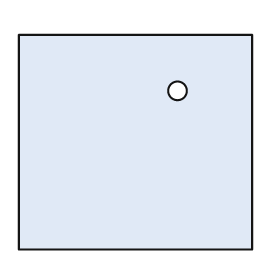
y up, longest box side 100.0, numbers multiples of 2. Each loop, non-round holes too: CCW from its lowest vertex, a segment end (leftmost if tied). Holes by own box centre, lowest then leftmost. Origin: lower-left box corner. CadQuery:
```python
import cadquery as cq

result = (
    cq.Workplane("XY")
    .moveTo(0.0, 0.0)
    .lineTo(100.0, 0.0)
    .lineTo(100.0, 92.0)
    .lineTo(0.0, 92.0)
    .close()
    .moveTo(68.0, 68.0)
    .circle(4.0)
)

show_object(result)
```